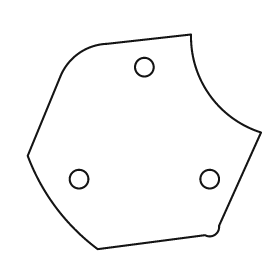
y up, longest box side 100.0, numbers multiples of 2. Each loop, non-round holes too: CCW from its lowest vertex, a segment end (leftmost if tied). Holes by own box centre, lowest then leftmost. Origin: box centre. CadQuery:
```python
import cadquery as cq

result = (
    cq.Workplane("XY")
    .moveTo(-20.0, -46.0)
    .lineTo(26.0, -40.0)
    .threePointArc((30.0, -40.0), (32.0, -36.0))
    .lineTo(50.0, 4.0)
    .threePointArc((28.0, 20.0), (20.0, 46.0))
    .lineTo(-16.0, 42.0)
    .threePointArc((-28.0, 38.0), (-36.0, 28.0))
    .lineTo(-50.0, -6.0)
    .threePointArc((-38.0, -28.0), (-20.0, -46.0))
    .close()
    .moveTo(-28.0, -16.0)
    .circle(4.0)
    .moveTo(28.0, -16.0)
    .circle(4.0)
    .moveTo(0.0, 32.0)
    .circle(4.0)
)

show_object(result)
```